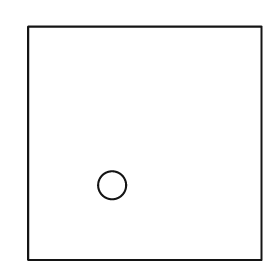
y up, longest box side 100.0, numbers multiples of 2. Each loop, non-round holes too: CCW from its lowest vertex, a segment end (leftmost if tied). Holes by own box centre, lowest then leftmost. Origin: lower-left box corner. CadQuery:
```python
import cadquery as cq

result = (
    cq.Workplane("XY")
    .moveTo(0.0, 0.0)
    .lineTo(100.0, 0.0)
    .lineTo(100.0, 100.0)
    .lineTo(0.0, 100.0)
    .close()
    .moveTo(36.0, 32.0)
    .circle(6.0)
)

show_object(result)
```